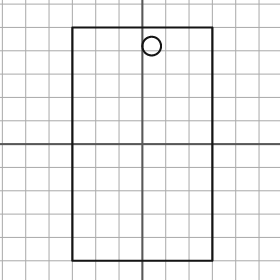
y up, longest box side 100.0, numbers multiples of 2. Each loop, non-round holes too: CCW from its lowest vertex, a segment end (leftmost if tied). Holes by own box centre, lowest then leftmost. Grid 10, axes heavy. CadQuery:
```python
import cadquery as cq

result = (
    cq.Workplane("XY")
    .moveTo(-30.0, -50.0)
    .lineTo(30.0, -50.0)
    .lineTo(30.0, 50.0)
    .lineTo(-30.0, 50.0)
    .close()
    .moveTo(4.0, 42.0)
    .circle(4.0)
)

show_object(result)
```